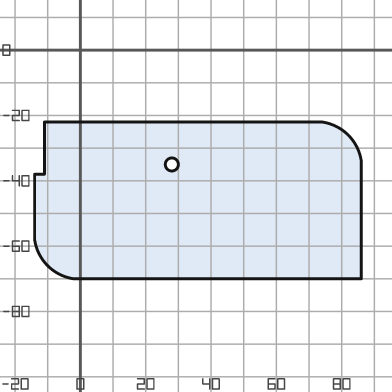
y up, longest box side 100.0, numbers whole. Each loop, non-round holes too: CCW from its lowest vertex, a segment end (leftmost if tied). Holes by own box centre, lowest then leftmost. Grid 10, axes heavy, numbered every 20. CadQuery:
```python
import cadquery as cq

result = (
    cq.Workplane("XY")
    .moveTo(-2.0, -70.0)
    .lineTo(86.0, -70.0)
    .lineTo(86.0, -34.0)
    .threePointArc((82.0, -26.0), (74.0, -22.0))
    .lineTo(-11.0, -22.0)
    .lineTo(-11.0, -38.0)
    .lineTo(-14.0, -38.0)
    .lineTo(-14.0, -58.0)
    .threePointArc((-10.0, -66.0), (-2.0, -70.0))
    .close()
    .moveTo(28.0, -35.0)
    .circle(2.0)
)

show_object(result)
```